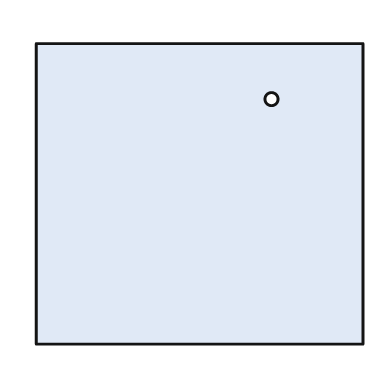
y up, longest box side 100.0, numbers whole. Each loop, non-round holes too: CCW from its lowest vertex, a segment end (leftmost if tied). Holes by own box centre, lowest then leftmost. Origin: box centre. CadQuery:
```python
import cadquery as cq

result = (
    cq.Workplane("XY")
    .moveTo(-50.0, -46.0)
    .lineTo(50.0, -46.0)
    .lineTo(50.0, 46.0)
    .lineTo(-50.0, 46.0)
    .close()
    .moveTo(22.0, 29.0)
    .circle(2.0)
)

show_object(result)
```